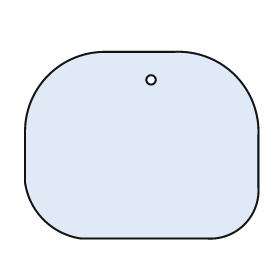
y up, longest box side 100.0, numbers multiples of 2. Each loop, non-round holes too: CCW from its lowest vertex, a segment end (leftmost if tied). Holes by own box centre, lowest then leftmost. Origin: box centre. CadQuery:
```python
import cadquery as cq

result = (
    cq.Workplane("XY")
    .moveTo(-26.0, -40.0)
    .lineTo(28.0, -40.0)
    .threePointArc((44.0, -34.0), (50.0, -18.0))
    .lineTo(50.0, 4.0)
    .threePointArc((40.0, 30.0), (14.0, 40.0))
    .lineTo(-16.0, 40.0)
    .threePointArc((-40.0, 30.0), (-50.0, 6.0))
    .lineTo(-50.0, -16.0)
    .threePointArc((-42.0, -32.0), (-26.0, -40.0))
    .close()
    .moveTo(4.0, 28.0)
    .circle(2.0)
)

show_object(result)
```